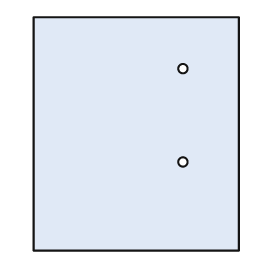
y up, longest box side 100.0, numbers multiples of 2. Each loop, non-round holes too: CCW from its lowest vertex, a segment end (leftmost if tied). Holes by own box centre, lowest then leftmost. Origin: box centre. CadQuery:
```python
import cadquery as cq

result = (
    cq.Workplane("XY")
    .moveTo(-44.0, -50.0)
    .lineTo(44.0, -50.0)
    .lineTo(44.0, 50.0)
    .lineTo(-44.0, 50.0)
    .close()
    .moveTo(20.0, -12.0)
    .circle(2.0)
    .moveTo(20.0, 28.0)
    .circle(2.0)
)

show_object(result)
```